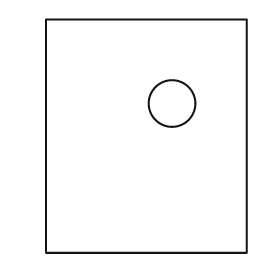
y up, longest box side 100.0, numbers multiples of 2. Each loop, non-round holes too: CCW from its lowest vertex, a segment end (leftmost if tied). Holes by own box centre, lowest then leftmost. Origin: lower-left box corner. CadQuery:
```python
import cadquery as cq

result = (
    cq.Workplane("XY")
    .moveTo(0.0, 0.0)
    .lineTo(86.0, 0.0)
    .lineTo(86.0, 100.0)
    .lineTo(0.0, 100.0)
    .close()
    .moveTo(54.0, 64.0)
    .circle(10.0)
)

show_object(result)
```